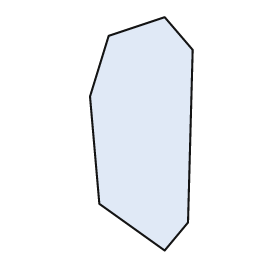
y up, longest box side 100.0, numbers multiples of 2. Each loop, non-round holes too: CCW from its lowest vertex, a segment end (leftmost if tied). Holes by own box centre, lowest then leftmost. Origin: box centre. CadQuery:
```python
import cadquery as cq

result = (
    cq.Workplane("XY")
    .moveTo(10.0, -50.0)
    .lineTo(20.0, -38.0)
    .lineTo(22.0, 36.0)
    .lineTo(10.0, 50.0)
    .lineTo(-14.0, 42.0)
    .lineTo(-22.0, 16.0)
    .lineTo(-18.0, -30.0)
    .close()
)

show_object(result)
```